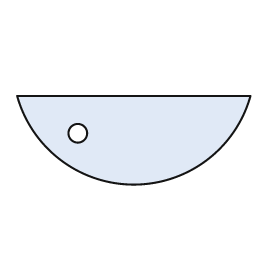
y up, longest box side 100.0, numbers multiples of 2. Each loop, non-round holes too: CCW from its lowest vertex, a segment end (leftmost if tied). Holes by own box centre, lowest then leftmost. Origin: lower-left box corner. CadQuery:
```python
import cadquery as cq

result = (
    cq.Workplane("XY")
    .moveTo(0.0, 38.0)
    .threePointArc((50.0, 0.0), (100.0, 38.0))
    .close()
    .moveTo(26.0, 22.0)
    .circle(4.0)
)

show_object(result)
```